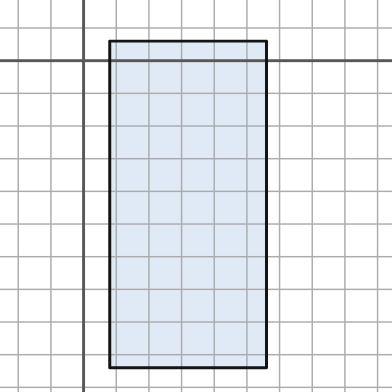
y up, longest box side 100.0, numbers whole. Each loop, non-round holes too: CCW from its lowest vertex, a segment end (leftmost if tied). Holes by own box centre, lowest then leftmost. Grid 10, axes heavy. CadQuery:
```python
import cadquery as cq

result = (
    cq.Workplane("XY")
    .moveTo(8.0, -94.0)
    .lineTo(56.0, -94.0)
    .lineTo(56.0, 6.0)
    .lineTo(8.0, 6.0)
    .close()
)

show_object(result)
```